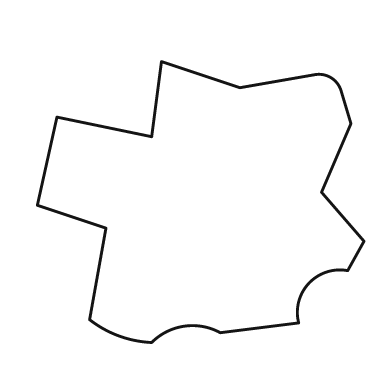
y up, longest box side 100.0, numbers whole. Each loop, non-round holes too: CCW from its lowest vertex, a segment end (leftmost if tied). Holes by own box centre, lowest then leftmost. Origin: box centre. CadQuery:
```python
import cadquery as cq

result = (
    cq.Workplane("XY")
    .moveTo(-15.0, -43.0)
    .threePointArc((-5.0, -38.0), (6.0, -40.0))
    .lineTo(30.0, -37.0)
    .threePointArc((33.0, -25.0), (45.0, -21.0))
    .lineTo(50.0, -12.0)
    .lineTo(37.0, 3.0)
    .lineTo(46.0, 24.0)
    .lineTo(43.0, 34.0)
    .threePointArc((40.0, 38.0), (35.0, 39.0))
    .lineTo(12.0, 35.0)
    .lineTo(-12.0, 43.0)
    .lineTo(-15.0, 20.0)
    .lineTo(-44.0, 26.0)
    .lineTo(-50.0, -1.0)
    .lineTo(-29.0, -8.0)
    .lineTo(-34.0, -36.0)
    .threePointArc((-25.0, -41.0), (-15.0, -43.0))
    .close()
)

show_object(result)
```